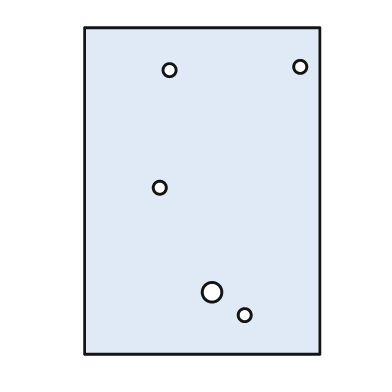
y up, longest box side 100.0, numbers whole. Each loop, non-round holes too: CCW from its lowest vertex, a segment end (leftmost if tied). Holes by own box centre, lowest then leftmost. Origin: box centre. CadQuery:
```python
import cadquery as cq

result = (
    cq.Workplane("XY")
    .moveTo(-36.0, -50.0)
    .lineTo(36.0, -50.0)
    .lineTo(36.0, 50.0)
    .lineTo(-36.0, 50.0)
    .close()
    .moveTo(13.0, -38.0)
    .circle(2.0)
    .moveTo(3.0, -31.0)
    .circle(3.0)
    .moveTo(-13.0, 1.0)
    .circle(2.0)
    .moveTo(-10.0, 37.0)
    .circle(2.0)
    .moveTo(30.0, 38.0)
    .circle(2.0)
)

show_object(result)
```